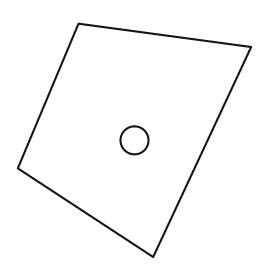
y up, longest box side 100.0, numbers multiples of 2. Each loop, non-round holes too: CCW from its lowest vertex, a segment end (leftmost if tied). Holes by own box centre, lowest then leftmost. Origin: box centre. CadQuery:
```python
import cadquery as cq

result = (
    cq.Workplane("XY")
    .moveTo(8.0, -50.0)
    .lineTo(50.0, 40.0)
    .lineTo(-24.0, 50.0)
    .lineTo(-50.0, -12.0)
    .close()
    .moveTo(0.0, 0.0)
    .circle(6.0)
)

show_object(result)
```